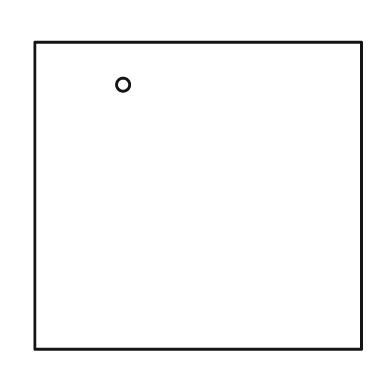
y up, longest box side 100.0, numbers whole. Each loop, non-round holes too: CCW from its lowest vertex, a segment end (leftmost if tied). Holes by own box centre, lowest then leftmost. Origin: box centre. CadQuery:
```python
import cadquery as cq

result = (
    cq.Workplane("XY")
    .moveTo(-50.0, -47.0)
    .lineTo(50.0, -47.0)
    .lineTo(50.0, 47.0)
    .lineTo(-50.0, 47.0)
    .close()
    .moveTo(-23.0, 34.0)
    .circle(2.0)
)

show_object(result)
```